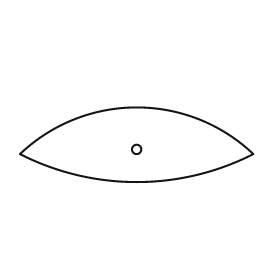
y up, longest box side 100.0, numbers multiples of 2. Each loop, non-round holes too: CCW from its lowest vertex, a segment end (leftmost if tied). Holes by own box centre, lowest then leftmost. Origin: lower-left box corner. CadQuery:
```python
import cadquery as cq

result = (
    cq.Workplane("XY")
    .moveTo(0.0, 12.0)
    .threePointArc((50.0, 0.0), (100.0, 12.0))
    .threePointArc((50.0, 32.0), (0.0, 12.0))
    .close()
    .moveTo(50.0, 14.0)
    .circle(2.0)
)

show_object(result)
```